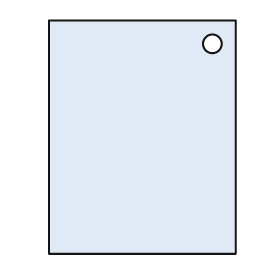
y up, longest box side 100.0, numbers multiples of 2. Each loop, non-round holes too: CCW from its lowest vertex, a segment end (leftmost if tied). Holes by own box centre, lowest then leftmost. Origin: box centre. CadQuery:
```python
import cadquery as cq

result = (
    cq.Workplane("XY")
    .moveTo(-40.0, -50.0)
    .lineTo(40.0, -50.0)
    .lineTo(40.0, 50.0)
    .lineTo(-40.0, 50.0)
    .close()
    .moveTo(30.0, 40.0)
    .circle(4.0)
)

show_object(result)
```